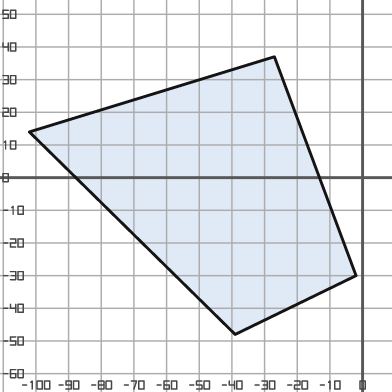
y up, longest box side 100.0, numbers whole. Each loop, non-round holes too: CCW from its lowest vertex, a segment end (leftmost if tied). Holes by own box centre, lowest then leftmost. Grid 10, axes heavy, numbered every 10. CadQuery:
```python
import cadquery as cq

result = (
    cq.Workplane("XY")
    .moveTo(-39.0, -48.0)
    .lineTo(-2.0, -30.0)
    .lineTo(-27.0, 37.0)
    .lineTo(-102.0, 14.0)
    .close()
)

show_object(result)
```